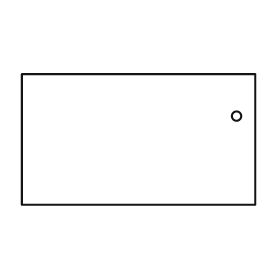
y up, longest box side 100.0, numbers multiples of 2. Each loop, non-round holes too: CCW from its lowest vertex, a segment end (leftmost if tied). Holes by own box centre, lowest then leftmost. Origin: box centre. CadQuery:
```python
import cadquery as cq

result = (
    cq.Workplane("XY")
    .moveTo(-50.0, -28.0)
    .lineTo(50.0, -28.0)
    .lineTo(50.0, 28.0)
    .lineTo(-50.0, 28.0)
    .close()
    .moveTo(42.0, 10.0)
    .circle(2.0)
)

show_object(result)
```